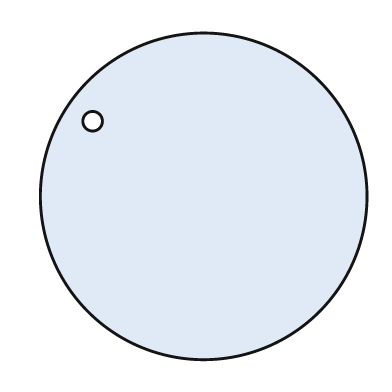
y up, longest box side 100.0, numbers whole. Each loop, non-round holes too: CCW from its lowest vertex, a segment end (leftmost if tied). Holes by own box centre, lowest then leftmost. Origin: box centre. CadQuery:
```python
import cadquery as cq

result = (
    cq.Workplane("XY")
    .moveTo(0.0, 0.0)
    .circle(50.0)
    .moveTo(-34.0, 23.0)
    .circle(3.0)
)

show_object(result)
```